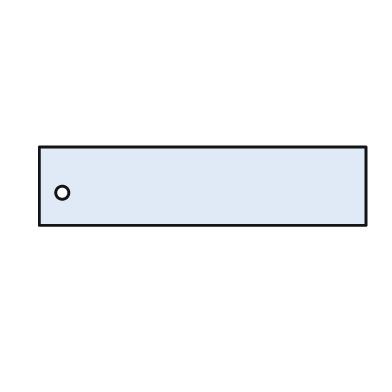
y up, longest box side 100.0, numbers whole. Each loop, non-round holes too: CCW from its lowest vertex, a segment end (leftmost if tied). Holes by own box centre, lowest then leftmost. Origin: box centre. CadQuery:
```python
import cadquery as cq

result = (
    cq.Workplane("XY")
    .moveTo(-50.0, -12.0)
    .lineTo(50.0, -12.0)
    .lineTo(50.0, 12.0)
    .lineTo(-50.0, 12.0)
    .close()
    .moveTo(-43.0, -2.0)
    .circle(2.0)
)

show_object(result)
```